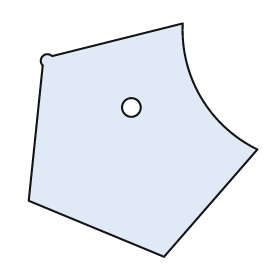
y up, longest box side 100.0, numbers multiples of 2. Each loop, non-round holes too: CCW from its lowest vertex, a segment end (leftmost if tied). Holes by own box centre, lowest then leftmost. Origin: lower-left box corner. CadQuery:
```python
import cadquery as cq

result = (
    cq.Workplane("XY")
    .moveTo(58.0, 0.0)
    .lineTo(98.0, 46.0)
    .threePointArc((74.0, 68.0), (66.0, 100.0))
    .lineTo(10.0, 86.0)
    .threePointArc((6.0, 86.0), (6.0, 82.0))
    .lineTo(0.0, 24.0)
    .close()
    .moveTo(44.0, 64.0)
    .circle(4.0)
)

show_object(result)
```